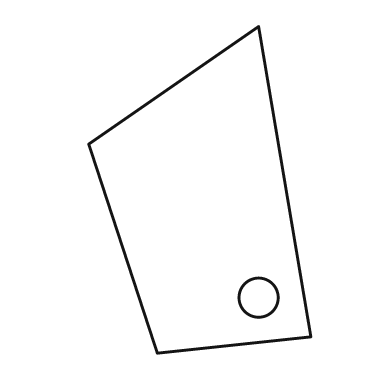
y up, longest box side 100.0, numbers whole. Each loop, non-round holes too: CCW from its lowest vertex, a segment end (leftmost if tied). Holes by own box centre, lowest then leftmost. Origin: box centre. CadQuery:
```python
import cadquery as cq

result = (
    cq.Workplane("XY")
    .moveTo(-13.0, -50.0)
    .lineTo(34.0, -45.0)
    .lineTo(18.0, 50.0)
    .lineTo(-34.0, 14.0)
    .close()
    .moveTo(18.0, -33.0)
    .circle(6.0)
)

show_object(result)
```